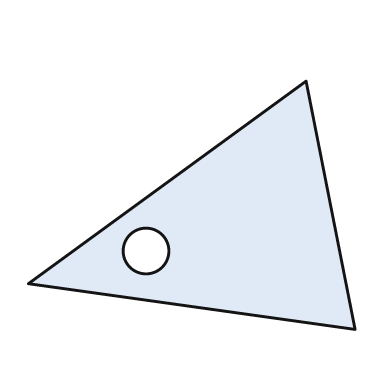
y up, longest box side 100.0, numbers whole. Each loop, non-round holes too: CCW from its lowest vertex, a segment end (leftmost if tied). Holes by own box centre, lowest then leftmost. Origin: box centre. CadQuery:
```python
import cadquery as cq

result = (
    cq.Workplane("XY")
    .moveTo(50.0, -38.0)
    .lineTo(35.0, 38.0)
    .lineTo(-50.0, -24.0)
    .close()
    .moveTo(-14.0, -14.0)
    .circle(7.0)
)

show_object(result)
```